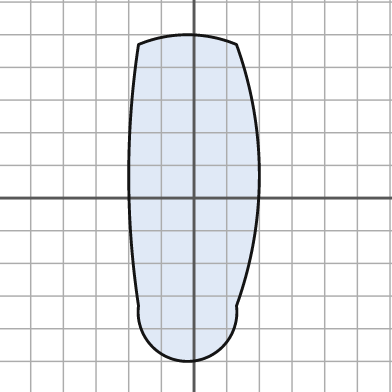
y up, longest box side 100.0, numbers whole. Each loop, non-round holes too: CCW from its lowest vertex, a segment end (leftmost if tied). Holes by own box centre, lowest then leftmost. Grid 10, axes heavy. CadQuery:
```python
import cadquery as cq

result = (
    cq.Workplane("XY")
    .moveTo(-17.0, -33.0)
    .threePointArc((-2.0, -50.0), (13.0, -33.0))
    .threePointArc((20.0, 7.0), (13.0, 47.0))
    .threePointArc((-2.0, 50.0), (-17.0, 47.0))
    .threePointArc((-20.0, 7.0), (-17.0, -33.0))
    .close()
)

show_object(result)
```